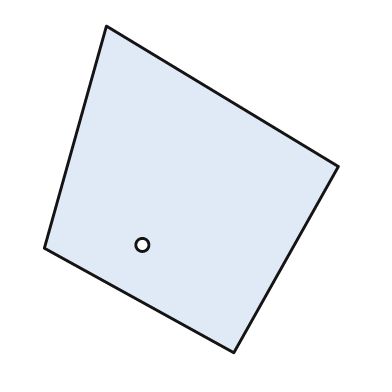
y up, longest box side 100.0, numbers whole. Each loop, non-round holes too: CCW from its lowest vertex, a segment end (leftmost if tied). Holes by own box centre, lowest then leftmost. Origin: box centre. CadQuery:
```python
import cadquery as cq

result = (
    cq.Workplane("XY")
    .moveTo(13.0, -50.0)
    .lineTo(45.0, 7.0)
    .lineTo(-26.0, 50.0)
    .lineTo(-45.0, -18.0)
    .close()
    .moveTo(-15.0, -17.0)
    .circle(2.0)
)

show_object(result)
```